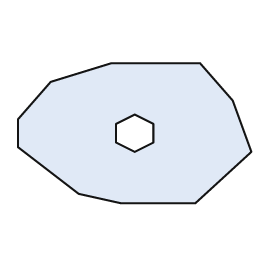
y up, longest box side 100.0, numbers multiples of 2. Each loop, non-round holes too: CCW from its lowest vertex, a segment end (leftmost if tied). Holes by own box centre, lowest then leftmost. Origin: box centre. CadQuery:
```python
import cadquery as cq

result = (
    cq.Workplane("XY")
    .moveTo(-6.0, -30.0)
    .lineTo(26.0, -30.0)
    .lineTo(50.0, -8.0)
    .lineTo(42.0, 14.0)
    .lineTo(28.0, 30.0)
    .lineTo(-10.0, 30.0)
    .lineTo(-36.0, 22.0)
    .lineTo(-50.0, 6.0)
    .lineTo(-50.0, -6.0)
    .lineTo(-24.0, -26.0)
    .close()
    .moveTo(0.0, -8.0)
    .lineTo(8.0, -4.0)
    .lineTo(8.0, 4.0)
    .lineTo(0.0, 8.0)
    .lineTo(-8.0, 4.0)
    .lineTo(-8.0, -4.0)
    .close()
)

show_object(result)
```